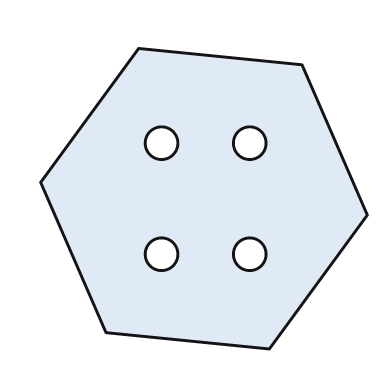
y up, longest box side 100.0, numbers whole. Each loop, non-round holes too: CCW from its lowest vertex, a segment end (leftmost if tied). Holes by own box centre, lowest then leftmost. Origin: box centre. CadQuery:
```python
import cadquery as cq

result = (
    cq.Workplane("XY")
    .moveTo(20.0, -46.0)
    .lineTo(50.0, -5.0)
    .lineTo(30.0, 41.0)
    .lineTo(-20.0, 46.0)
    .lineTo(-50.0, 5.0)
    .lineTo(-30.0, -41.0)
    .close()
    .moveTo(-13.0, -17.0)
    .circle(5.0)
    .moveTo(14.0, -17.0)
    .circle(5.0)
    .moveTo(-13.0, 17.0)
    .circle(5.0)
    .moveTo(14.0, 17.0)
    .circle(5.0)
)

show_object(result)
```